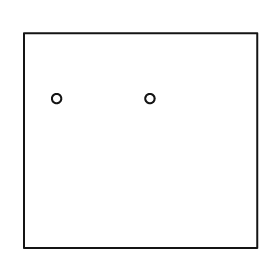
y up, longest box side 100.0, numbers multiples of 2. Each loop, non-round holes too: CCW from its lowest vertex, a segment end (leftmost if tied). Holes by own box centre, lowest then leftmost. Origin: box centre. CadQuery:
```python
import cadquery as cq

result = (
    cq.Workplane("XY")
    .moveTo(-50.0, -46.0)
    .lineTo(50.0, -46.0)
    .lineTo(50.0, 46.0)
    .lineTo(-50.0, 46.0)
    .close()
    .moveTo(-36.0, 18.0)
    .circle(2.0)
    .moveTo(4.0, 18.0)
    .circle(2.0)
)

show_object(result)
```